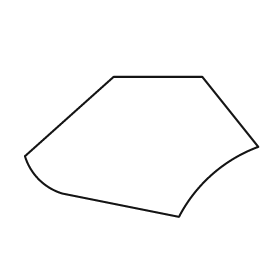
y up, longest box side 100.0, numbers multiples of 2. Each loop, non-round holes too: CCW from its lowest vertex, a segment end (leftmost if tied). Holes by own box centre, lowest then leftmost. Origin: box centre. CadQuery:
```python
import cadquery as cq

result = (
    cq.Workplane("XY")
    .moveTo(16.0, -30.0)
    .threePointArc((30.0, -12.0), (50.0, 0.0))
    .lineTo(26.0, 30.0)
    .lineTo(-12.0, 30.0)
    .lineTo(-50.0, -4.0)
    .threePointArc((-44.0, -14.0), (-34.0, -20.0))
    .close()
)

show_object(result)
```